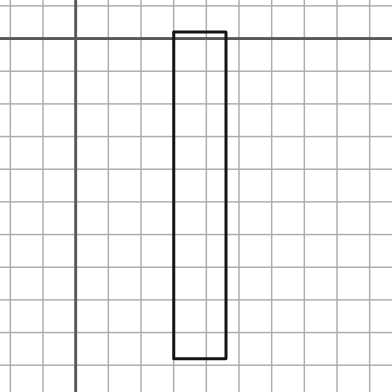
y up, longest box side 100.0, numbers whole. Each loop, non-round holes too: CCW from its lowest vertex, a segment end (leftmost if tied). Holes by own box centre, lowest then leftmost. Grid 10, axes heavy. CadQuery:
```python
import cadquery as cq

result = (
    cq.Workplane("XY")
    .moveTo(30.0, -98.0)
    .lineTo(46.0, -98.0)
    .lineTo(46.0, 2.0)
    .lineTo(30.0, 2.0)
    .close()
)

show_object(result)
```